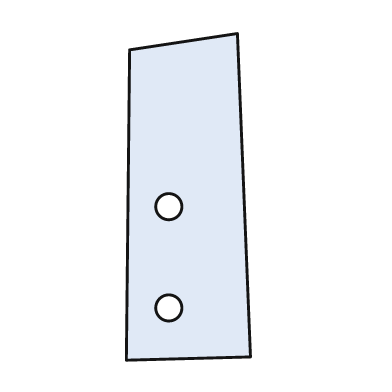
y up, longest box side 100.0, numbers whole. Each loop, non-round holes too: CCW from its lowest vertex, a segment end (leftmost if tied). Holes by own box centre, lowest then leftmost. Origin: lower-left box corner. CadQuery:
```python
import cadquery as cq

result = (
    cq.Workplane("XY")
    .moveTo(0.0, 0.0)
    .lineTo(38.0, 1.0)
    .lineTo(34.0, 100.0)
    .lineTo(1.0, 95.0)
    .close()
    .moveTo(13.0, 16.0)
    .circle(4.0)
    .moveTo(13.0, 47.0)
    .circle(4.0)
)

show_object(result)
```